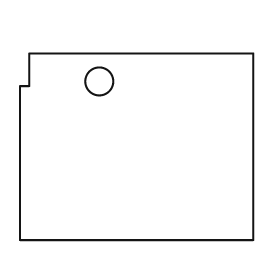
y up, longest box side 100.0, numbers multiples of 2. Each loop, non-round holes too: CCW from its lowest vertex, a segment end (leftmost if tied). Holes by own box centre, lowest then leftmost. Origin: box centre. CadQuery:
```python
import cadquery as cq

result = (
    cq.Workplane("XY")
    .moveTo(-50.0, -40.0)
    .lineTo(50.0, -40.0)
    .lineTo(50.0, 40.0)
    .lineTo(-46.0, 40.0)
    .lineTo(-46.0, 26.0)
    .lineTo(-50.0, 26.0)
    .close()
    .moveTo(-16.0, 28.0)
    .circle(6.0)
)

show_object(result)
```